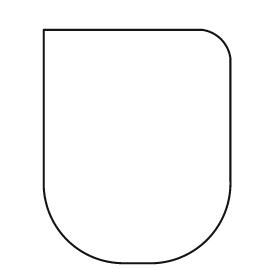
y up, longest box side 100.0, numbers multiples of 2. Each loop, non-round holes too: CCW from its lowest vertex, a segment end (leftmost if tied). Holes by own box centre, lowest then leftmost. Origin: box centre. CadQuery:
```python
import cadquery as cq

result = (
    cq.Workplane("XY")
    .moveTo(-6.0, -50.0)
    .lineTo(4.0, -50.0)
    .threePointArc((30.0, -40.0), (40.0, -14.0))
    .lineTo(40.0, 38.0)
    .threePointArc((36.0, 46.0), (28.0, 50.0))
    .lineTo(-40.0, 50.0)
    .lineTo(-40.0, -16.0)
    .threePointArc((-30.0, -40.0), (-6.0, -50.0))
    .close()
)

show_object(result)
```